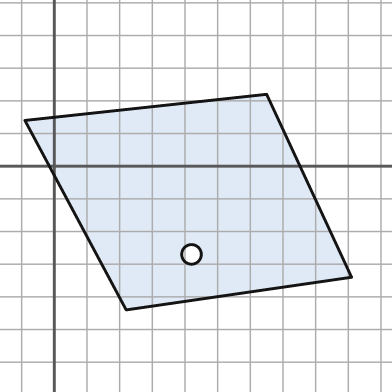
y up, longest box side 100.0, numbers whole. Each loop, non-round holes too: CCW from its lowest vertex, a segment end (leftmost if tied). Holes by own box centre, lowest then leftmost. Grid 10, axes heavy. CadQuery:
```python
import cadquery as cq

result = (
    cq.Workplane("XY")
    .moveTo(22.0, -44.0)
    .lineTo(91.0, -34.0)
    .lineTo(65.0, 22.0)
    .lineTo(-9.0, 14.0)
    .close()
    .moveTo(42.0, -27.0)
    .circle(3.0)
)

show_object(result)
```